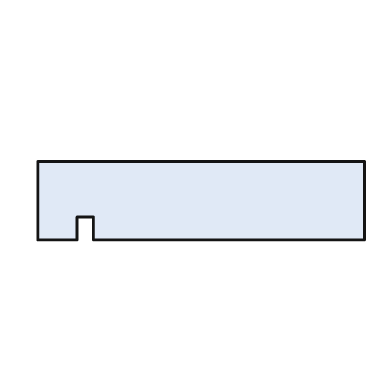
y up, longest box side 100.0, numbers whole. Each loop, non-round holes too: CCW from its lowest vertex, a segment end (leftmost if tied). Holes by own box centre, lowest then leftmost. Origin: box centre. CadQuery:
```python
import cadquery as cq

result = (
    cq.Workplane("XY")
    .moveTo(-50.0, -12.0)
    .lineTo(-38.0, -12.0)
    .lineTo(-38.0, -5.0)
    .lineTo(-33.0, -5.0)
    .lineTo(-33.0, -12.0)
    .lineTo(50.0, -12.0)
    .lineTo(50.0, 12.0)
    .lineTo(-50.0, 12.0)
    .close()
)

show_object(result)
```